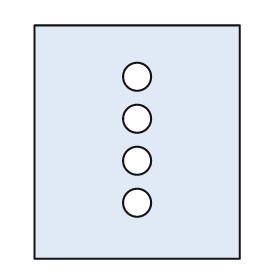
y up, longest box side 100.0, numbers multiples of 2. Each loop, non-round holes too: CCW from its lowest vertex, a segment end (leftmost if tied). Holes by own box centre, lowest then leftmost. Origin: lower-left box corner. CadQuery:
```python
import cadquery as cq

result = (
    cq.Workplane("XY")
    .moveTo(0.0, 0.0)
    .lineTo(88.0, 0.0)
    .lineTo(88.0, 100.0)
    .lineTo(0.0, 100.0)
    .close()
    .moveTo(44.0, 24.0)
    .circle(6.0)
    .moveTo(44.0, 42.0)
    .circle(6.0)
    .moveTo(44.0, 60.0)
    .circle(6.0)
    .moveTo(44.0, 78.0)
    .circle(6.0)
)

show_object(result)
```